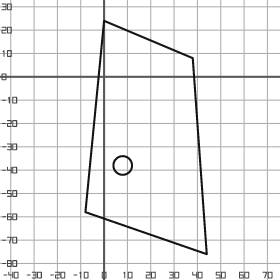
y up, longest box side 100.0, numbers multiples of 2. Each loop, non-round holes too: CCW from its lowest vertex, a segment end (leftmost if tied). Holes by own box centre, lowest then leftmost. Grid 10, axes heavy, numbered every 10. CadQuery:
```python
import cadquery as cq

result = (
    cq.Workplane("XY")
    .moveTo(44.0, -76.0)
    .lineTo(38.0, 8.0)
    .lineTo(0.0, 24.0)
    .lineTo(-8.0, -58.0)
    .close()
    .moveTo(8.0, -38.0)
    .circle(4.0)
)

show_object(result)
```